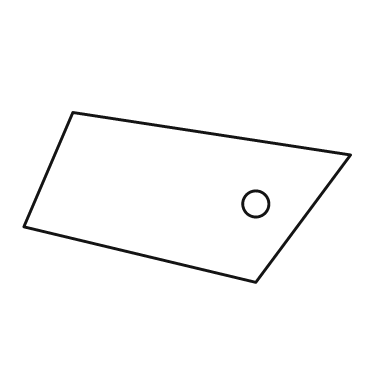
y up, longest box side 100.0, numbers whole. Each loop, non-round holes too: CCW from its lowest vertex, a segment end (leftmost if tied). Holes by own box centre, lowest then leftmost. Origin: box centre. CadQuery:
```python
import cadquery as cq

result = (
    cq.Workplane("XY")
    .moveTo(21.0, -26.0)
    .lineTo(50.0, 13.0)
    .lineTo(-35.0, 26.0)
    .lineTo(-50.0, -9.0)
    .close()
    .moveTo(21.0, -2.0)
    .circle(4.0)
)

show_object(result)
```